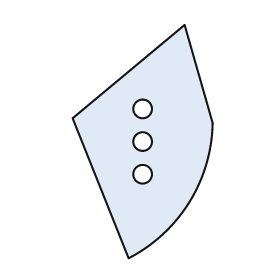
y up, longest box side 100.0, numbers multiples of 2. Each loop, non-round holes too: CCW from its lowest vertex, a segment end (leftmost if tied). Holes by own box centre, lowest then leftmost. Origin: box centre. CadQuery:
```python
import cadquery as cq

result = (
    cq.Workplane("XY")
    .moveTo(-6.0, -50.0)
    .threePointArc((20.0, -26.0), (30.0, 8.0))
    .lineTo(18.0, 50.0)
    .lineTo(-30.0, 10.0)
    .close()
    .moveTo(0.0, -14.0)
    .circle(4.0)
    .moveTo(0.0, 0.0)
    .circle(4.0)
    .moveTo(0.0, 14.0)
    .circle(4.0)
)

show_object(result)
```